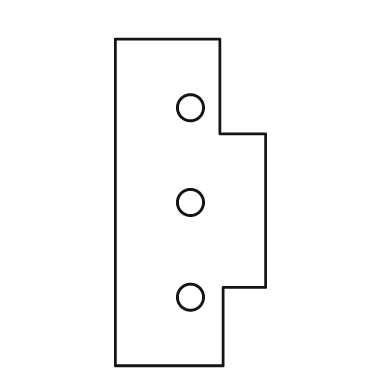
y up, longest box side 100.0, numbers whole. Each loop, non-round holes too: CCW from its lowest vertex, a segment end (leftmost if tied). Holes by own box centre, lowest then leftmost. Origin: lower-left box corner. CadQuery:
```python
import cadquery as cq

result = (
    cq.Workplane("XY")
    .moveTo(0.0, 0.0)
    .lineTo(33.0, 0.0)
    .lineTo(33.0, 24.0)
    .lineTo(46.0, 24.0)
    .lineTo(46.0, 71.0)
    .lineTo(32.0, 71.0)
    .lineTo(32.0, 100.0)
    .lineTo(0.0, 100.0)
    .close()
    .moveTo(23.0, 21.0)
    .circle(4.0)
    .moveTo(23.0, 50.0)
    .circle(4.0)
    .moveTo(23.0, 79.0)
    .circle(4.0)
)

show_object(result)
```